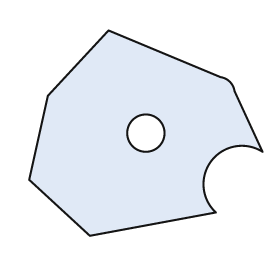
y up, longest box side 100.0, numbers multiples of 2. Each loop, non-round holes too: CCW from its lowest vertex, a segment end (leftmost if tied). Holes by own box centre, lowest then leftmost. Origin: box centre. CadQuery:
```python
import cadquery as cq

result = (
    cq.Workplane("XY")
    .moveTo(-24.0, -44.0)
    .lineTo(30.0, -34.0)
    .threePointArc((28.0, -12.0), (50.0, -8.0))
    .lineTo(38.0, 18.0)
    .threePointArc((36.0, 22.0), (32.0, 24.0))
    .lineTo(-16.0, 44.0)
    .lineTo(-42.0, 16.0)
    .lineTo(-50.0, -20.0)
    .close()
    .moveTo(0.0, 0.0)
    .circle(8.0)
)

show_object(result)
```